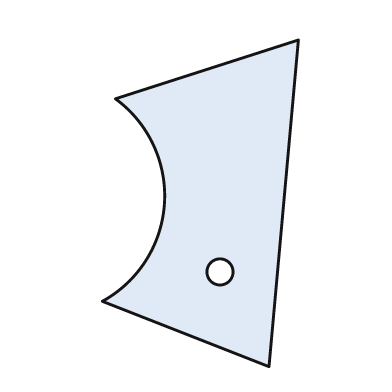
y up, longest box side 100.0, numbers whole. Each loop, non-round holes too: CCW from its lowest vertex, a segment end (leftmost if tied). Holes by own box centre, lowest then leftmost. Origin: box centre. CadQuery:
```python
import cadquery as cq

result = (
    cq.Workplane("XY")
    .moveTo(21.0, -50.0)
    .lineTo(30.0, 50.0)
    .lineTo(-26.0, 32.0)
    .threePointArc((-11.0, 0.0), (-30.0, -30.0))
    .close()
    .moveTo(6.0, -21.0)
    .circle(4.0)
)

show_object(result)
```